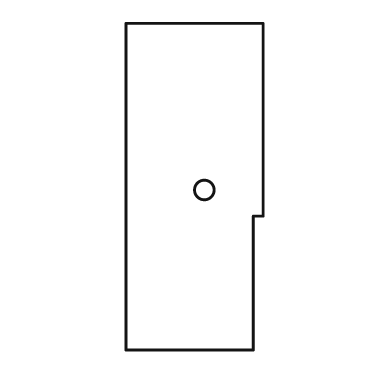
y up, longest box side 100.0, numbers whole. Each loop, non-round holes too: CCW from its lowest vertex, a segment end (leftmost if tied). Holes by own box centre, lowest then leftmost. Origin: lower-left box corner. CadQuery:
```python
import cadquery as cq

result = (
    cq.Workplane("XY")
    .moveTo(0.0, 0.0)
    .lineTo(39.0, 0.0)
    .lineTo(39.0, 41.0)
    .lineTo(42.0, 41.0)
    .lineTo(42.0, 100.0)
    .lineTo(0.0, 100.0)
    .close()
    .moveTo(24.0, 49.0)
    .circle(3.0)
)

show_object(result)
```